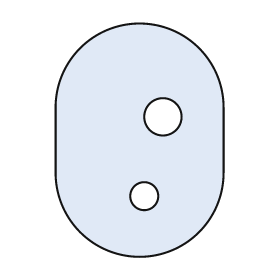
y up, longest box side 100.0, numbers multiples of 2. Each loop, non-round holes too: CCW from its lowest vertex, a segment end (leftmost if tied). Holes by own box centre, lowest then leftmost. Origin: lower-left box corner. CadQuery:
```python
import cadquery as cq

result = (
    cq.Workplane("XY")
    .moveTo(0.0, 36.0)
    .threePointArc((36.0, 0.0), (72.0, 36.0))
    .lineTo(72.0, 64.0)
    .threePointArc((36.0, 100.0), (0.0, 64.0))
    .close()
    .moveTo(38.0, 26.0)
    .circle(6.0)
    .moveTo(46.0, 60.0)
    .circle(8.0)
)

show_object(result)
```